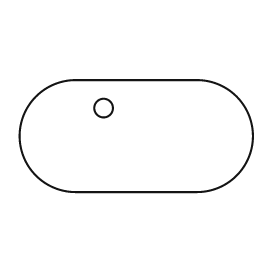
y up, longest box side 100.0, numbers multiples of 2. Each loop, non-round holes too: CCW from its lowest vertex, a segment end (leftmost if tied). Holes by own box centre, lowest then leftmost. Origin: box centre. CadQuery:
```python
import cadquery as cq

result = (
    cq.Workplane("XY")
    .moveTo(-26.0, -24.0)
    .lineTo(26.0, -24.0)
    .threePointArc((50.0, 0.0), (26.0, 24.0))
    .lineTo(-26.0, 24.0)
    .threePointArc((-50.0, 0.0), (-26.0, -24.0))
    .close()
    .moveTo(-14.0, 12.0)
    .circle(4.0)
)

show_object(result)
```